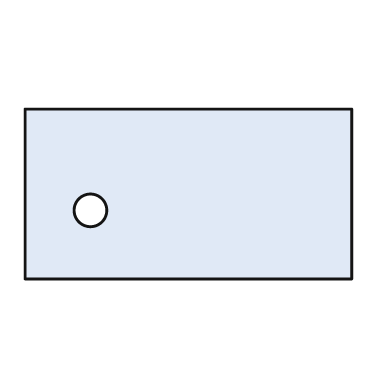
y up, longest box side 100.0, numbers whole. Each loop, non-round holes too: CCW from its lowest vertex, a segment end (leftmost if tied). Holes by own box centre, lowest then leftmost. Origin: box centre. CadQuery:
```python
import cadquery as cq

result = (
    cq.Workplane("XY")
    .moveTo(-50.0, -26.0)
    .lineTo(50.0, -26.0)
    .lineTo(50.0, 26.0)
    .lineTo(-50.0, 26.0)
    .close()
    .moveTo(-30.0, -5.0)
    .circle(5.0)
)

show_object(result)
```